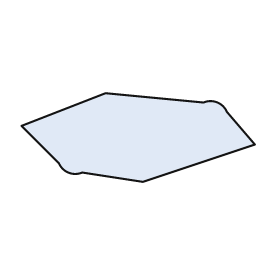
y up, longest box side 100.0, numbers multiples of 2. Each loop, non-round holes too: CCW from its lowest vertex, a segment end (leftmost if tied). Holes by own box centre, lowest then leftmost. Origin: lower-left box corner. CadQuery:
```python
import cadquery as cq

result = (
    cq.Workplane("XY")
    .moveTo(52.0, 0.0)
    .lineTo(100.0, 16.0)
    .lineTo(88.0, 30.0)
    .threePointArc((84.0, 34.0), (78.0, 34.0))
    .lineTo(36.0, 38.0)
    .lineTo(0.0, 24.0)
    .lineTo(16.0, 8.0)
    .threePointArc((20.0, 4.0), (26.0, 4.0))
    .close()
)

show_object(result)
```